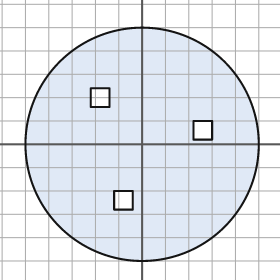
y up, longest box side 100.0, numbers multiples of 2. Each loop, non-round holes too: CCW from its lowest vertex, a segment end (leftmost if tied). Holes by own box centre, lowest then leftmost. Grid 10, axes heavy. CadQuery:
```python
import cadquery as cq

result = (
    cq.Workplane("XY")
    .moveTo(0.0, 0.0)
    .circle(50.0)
    .moveTo(-12.0, -28.0)
    .lineTo(-4.0, -28.0)
    .lineTo(-4.0, -20.0)
    .lineTo(-12.0, -20.0)
    .close()
    .moveTo(22.0, 2.0)
    .lineTo(30.0, 2.0)
    .lineTo(30.0, 10.0)
    .lineTo(22.0, 10.0)
    .close()
    .moveTo(-22.0, 16.0)
    .lineTo(-14.0, 16.0)
    .lineTo(-14.0, 24.0)
    .lineTo(-22.0, 24.0)
    .close()
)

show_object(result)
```